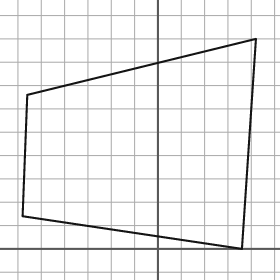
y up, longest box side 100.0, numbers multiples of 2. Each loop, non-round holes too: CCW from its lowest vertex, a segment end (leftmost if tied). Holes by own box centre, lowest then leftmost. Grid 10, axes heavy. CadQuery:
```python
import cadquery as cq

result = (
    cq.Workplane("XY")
    .moveTo(36.0, 0.0)
    .lineTo(42.0, 90.0)
    .lineTo(-56.0, 66.0)
    .lineTo(-58.0, 14.0)
    .close()
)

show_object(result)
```